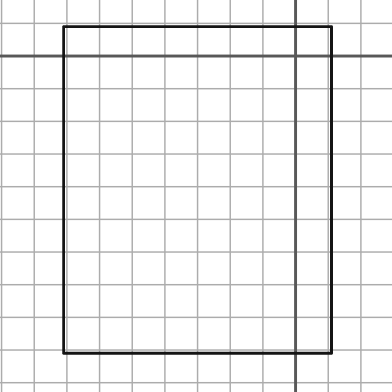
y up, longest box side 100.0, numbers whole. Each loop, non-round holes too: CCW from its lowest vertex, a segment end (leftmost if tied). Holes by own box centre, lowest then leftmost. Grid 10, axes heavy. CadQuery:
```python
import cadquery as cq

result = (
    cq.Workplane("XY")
    .moveTo(-71.0, -91.0)
    .lineTo(11.0, -91.0)
    .lineTo(11.0, 9.0)
    .lineTo(-71.0, 9.0)
    .close()
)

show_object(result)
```